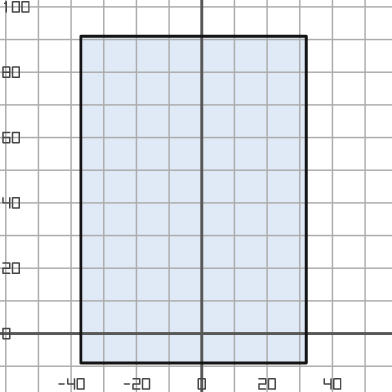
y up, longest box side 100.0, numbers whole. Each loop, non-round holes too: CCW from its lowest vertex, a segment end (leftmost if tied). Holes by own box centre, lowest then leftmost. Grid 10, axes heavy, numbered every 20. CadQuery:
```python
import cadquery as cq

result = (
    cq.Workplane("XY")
    .moveTo(-37.0, -9.0)
    .lineTo(32.0, -9.0)
    .lineTo(32.0, 91.0)
    .lineTo(-37.0, 91.0)
    .close()
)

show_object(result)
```